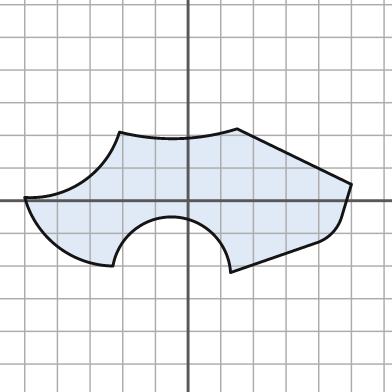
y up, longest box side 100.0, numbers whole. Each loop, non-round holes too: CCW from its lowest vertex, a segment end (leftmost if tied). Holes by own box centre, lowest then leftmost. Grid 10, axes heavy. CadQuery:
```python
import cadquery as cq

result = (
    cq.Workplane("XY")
    .moveTo(13.0, -22.0)
    .lineTo(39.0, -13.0)
    .threePointArc((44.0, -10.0), (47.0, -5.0))
    .lineTo(50.0, 5.0)
    .lineTo(15.0, 22.0)
    .threePointArc((-3.0, 19.0), (-21.0, 21.0))
    .threePointArc((-32.0, 6.0), (-50.0, 1.0))
    .threePointArc((-40.0, -14.0), (-23.0, -20.0))
    .threePointArc((-4.0, -5.0), (13.0, -22.0))
    .close()
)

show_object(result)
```